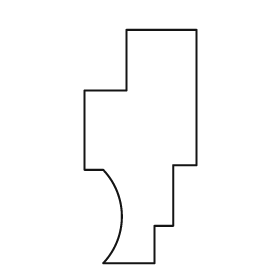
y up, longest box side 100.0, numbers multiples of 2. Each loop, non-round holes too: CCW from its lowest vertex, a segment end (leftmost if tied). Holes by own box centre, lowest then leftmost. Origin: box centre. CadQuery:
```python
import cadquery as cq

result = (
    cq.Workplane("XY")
    .moveTo(-16.0, -50.0)
    .lineTo(6.0, -50.0)
    .lineTo(6.0, -34.0)
    .lineTo(14.0, -34.0)
    .lineTo(14.0, -8.0)
    .lineTo(24.0, -8.0)
    .lineTo(24.0, 50.0)
    .lineTo(-6.0, 50.0)
    .lineTo(-6.0, 24.0)
    .lineTo(-24.0, 24.0)
    .lineTo(-24.0, -10.0)
    .lineTo(-16.0, -10.0)
    .threePointArc((-8.0, -30.0), (-16.0, -50.0))
    .close()
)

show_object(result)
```